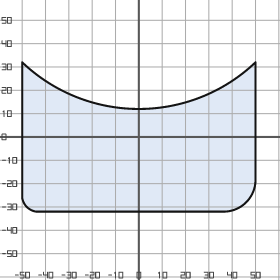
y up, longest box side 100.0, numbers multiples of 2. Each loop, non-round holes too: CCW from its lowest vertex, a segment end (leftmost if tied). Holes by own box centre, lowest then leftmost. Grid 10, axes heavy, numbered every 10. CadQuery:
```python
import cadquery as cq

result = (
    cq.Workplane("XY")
    .moveTo(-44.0, -32.0)
    .lineTo(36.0, -32.0)
    .threePointArc((46.0, -28.0), (50.0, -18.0))
    .lineTo(50.0, 32.0)
    .threePointArc((0.0, 12.0), (-50.0, 32.0))
    .lineTo(-50.0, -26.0)
    .threePointArc((-48.0, -30.0), (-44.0, -32.0))
    .close()
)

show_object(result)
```